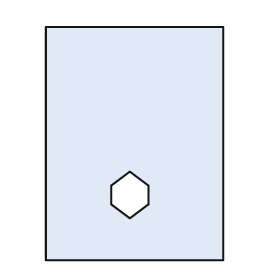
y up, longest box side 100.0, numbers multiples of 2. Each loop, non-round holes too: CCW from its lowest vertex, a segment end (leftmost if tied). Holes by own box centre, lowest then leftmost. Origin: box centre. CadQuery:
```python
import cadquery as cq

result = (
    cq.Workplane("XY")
    .moveTo(-38.0, -50.0)
    .lineTo(38.0, -50.0)
    .lineTo(38.0, 50.0)
    .lineTo(-38.0, 50.0)
    .close()
    .moveTo(-2.0, -32.0)
    .lineTo(6.0, -26.0)
    .lineTo(6.0, -18.0)
    .lineTo(-2.0, -12.0)
    .lineTo(-10.0, -18.0)
    .lineTo(-10.0, -26.0)
    .close()
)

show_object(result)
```